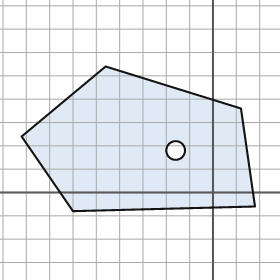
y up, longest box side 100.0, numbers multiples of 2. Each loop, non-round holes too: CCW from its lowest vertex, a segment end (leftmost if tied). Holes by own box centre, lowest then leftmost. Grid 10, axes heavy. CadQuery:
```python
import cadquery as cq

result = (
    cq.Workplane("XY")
    .moveTo(-60.0, -8.0)
    .lineTo(18.0, -6.0)
    .lineTo(12.0, 36.0)
    .lineTo(-46.0, 54.0)
    .lineTo(-82.0, 24.0)
    .close()
    .moveTo(-16.0, 18.0)
    .circle(4.0)
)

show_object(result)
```